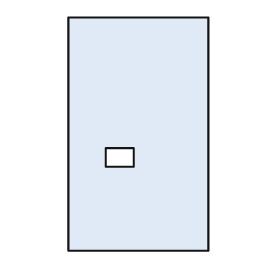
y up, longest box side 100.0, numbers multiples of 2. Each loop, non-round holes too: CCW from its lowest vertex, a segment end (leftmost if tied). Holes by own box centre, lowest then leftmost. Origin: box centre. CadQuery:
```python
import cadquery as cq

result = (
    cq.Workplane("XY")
    .moveTo(-30.0, -50.0)
    .lineTo(30.0, -50.0)
    .lineTo(30.0, 50.0)
    .lineTo(-30.0, 50.0)
    .close()
    .moveTo(-14.0, -14.0)
    .lineTo(-2.0, -14.0)
    .lineTo(-2.0, -6.0)
    .lineTo(-14.0, -6.0)
    .close()
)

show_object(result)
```